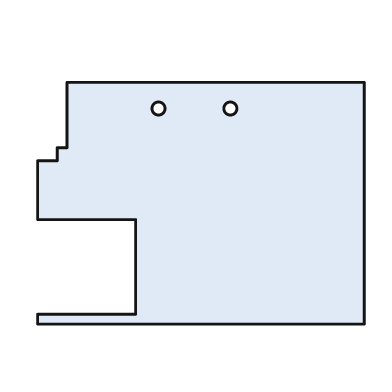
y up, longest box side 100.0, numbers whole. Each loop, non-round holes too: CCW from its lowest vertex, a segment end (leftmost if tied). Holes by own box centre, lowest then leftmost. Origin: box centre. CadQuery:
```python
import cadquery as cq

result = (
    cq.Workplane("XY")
    .moveTo(-50.0, -37.0)
    .lineTo(50.0, -37.0)
    .lineTo(50.0, 37.0)
    .lineTo(-41.0, 37.0)
    .lineTo(-41.0, 17.0)
    .lineTo(-44.0, 17.0)
    .lineTo(-44.0, 13.0)
    .lineTo(-50.0, 13.0)
    .lineTo(-50.0, -5.0)
    .lineTo(-20.0, -5.0)
    .lineTo(-20.0, -34.0)
    .lineTo(-50.0, -34.0)
    .close()
    .moveTo(-13.0, 29.0)
    .circle(2.0)
    .moveTo(9.0, 29.0)
    .circle(2.0)
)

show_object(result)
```